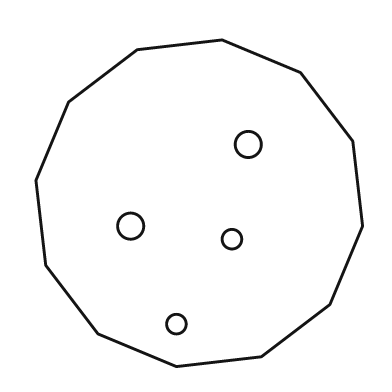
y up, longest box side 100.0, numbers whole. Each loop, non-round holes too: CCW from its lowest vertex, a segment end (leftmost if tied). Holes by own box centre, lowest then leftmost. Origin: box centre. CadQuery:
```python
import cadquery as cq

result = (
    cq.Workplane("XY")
    .moveTo(-7.0, -50.0)
    .lineTo(19.0, -47.0)
    .lineTo(40.0, -31.0)
    .lineTo(50.0, -7.0)
    .lineTo(47.0, 19.0)
    .lineTo(31.0, 40.0)
    .lineTo(7.0, 50.0)
    .lineTo(-19.0, 47.0)
    .lineTo(-40.0, 31.0)
    .lineTo(-50.0, 7.0)
    .lineTo(-47.0, -19.0)
    .lineTo(-31.0, -40.0)
    .close()
    .moveTo(-7.0, -37.0)
    .circle(3.0)
    .moveTo(10.0, -11.0)
    .circle(3.0)
    .moveTo(-21.0, -7.0)
    .circle(4.0)
    .moveTo(15.0, 18.0)
    .circle(4.0)
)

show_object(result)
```